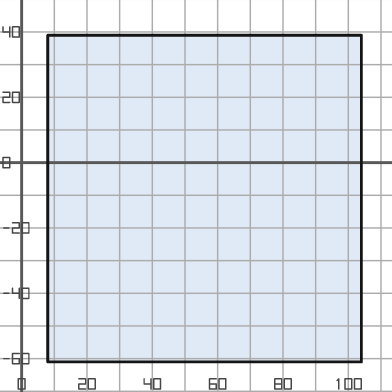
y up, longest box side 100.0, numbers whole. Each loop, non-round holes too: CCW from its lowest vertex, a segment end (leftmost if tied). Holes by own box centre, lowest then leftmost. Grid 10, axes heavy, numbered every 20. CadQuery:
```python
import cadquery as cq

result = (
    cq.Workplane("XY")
    .moveTo(8.0, -61.0)
    .lineTo(104.0, -61.0)
    .lineTo(104.0, 39.0)
    .lineTo(8.0, 39.0)
    .close()
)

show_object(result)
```